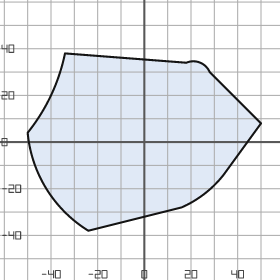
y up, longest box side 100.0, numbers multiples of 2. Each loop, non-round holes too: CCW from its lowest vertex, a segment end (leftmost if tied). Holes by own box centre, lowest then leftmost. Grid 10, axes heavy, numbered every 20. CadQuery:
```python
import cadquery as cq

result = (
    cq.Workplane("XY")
    .moveTo(-24.0, -38.0)
    .lineTo(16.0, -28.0)
    .threePointArc((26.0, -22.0), (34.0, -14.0))
    .lineTo(50.0, 8.0)
    .lineTo(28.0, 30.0)
    .threePointArc((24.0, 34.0), (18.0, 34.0))
    .lineTo(-34.0, 38.0)
    .threePointArc((-40.0, 20.0), (-50.0, 4.0))
    .threePointArc((-42.0, -20.0), (-24.0, -38.0))
    .close()
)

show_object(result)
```